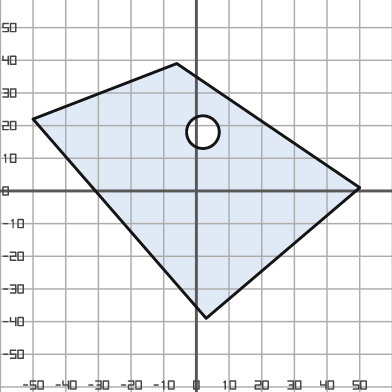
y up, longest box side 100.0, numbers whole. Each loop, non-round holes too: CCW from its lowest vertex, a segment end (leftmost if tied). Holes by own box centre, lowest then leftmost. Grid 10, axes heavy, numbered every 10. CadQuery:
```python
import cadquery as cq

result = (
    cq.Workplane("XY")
    .moveTo(3.0, -39.0)
    .lineTo(50.0, 1.0)
    .lineTo(-6.0, 39.0)
    .lineTo(-50.0, 22.0)
    .close()
    .moveTo(2.0, 18.0)
    .circle(5.0)
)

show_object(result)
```